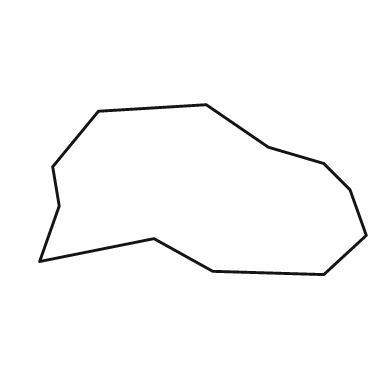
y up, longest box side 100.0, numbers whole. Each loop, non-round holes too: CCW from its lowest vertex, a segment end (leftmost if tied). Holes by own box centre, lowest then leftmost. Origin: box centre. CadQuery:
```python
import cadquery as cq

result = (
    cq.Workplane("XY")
    .moveTo(37.0, -26.0)
    .lineTo(50.0, -14.0)
    .lineTo(45.0, 0.0)
    .lineTo(37.0, 8.0)
    .lineTo(20.0, 13.0)
    .lineTo(1.0, 26.0)
    .lineTo(-32.0, 24.0)
    .lineTo(-46.0, 7.0)
    .lineTo(-44.0, -5.0)
    .lineTo(-50.0, -22.0)
    .lineTo(-15.0, -15.0)
    .lineTo(3.0, -25.0)
    .close()
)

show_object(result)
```